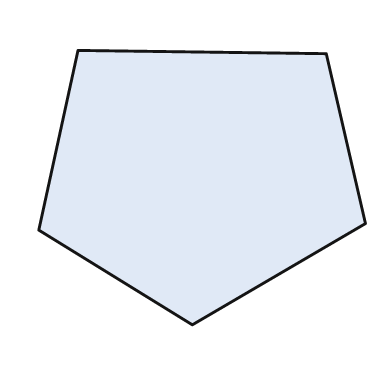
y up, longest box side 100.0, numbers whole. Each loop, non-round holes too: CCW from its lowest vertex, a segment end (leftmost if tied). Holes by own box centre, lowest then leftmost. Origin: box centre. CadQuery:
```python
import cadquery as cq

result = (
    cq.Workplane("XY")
    .moveTo(-3.0, -42.0)
    .lineTo(50.0, -11.0)
    .lineTo(38.0, 41.0)
    .lineTo(-38.0, 42.0)
    .lineTo(-50.0, -13.0)
    .close()
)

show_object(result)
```